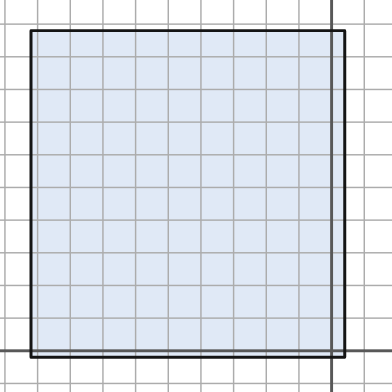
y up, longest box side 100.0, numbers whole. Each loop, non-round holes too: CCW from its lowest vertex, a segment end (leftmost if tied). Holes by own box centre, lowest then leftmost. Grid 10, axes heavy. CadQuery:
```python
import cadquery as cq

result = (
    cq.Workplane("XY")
    .moveTo(-92.0, -2.0)
    .lineTo(4.0, -2.0)
    .lineTo(4.0, 98.0)
    .lineTo(-92.0, 98.0)
    .close()
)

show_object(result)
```